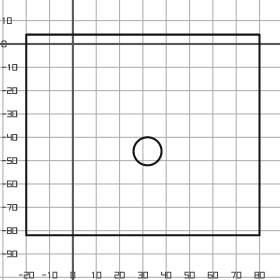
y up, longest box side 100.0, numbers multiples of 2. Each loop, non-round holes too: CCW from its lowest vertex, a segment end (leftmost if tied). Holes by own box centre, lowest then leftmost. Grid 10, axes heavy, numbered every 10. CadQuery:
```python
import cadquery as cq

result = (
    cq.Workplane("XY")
    .moveTo(-20.0, -82.0)
    .lineTo(80.0, -82.0)
    .lineTo(80.0, 4.0)
    .lineTo(-20.0, 4.0)
    .close()
    .moveTo(32.0, -46.0)
    .circle(6.0)
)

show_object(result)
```